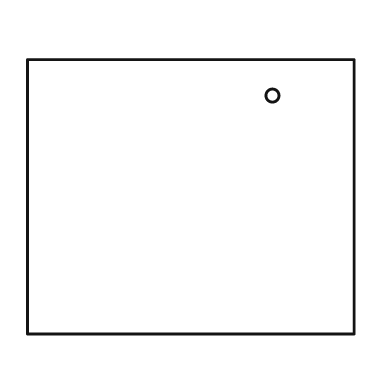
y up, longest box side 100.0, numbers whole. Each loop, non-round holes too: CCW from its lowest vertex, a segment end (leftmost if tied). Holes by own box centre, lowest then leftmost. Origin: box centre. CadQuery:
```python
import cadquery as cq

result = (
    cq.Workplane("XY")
    .moveTo(-50.0, -42.0)
    .lineTo(50.0, -42.0)
    .lineTo(50.0, 42.0)
    .lineTo(-50.0, 42.0)
    .close()
    .moveTo(25.0, 31.0)
    .circle(2.0)
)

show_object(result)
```